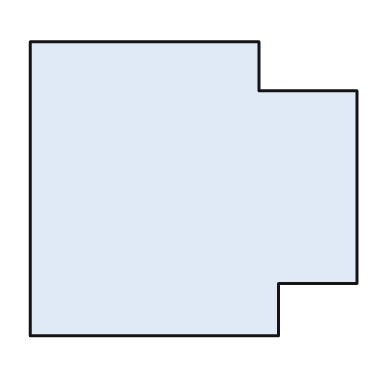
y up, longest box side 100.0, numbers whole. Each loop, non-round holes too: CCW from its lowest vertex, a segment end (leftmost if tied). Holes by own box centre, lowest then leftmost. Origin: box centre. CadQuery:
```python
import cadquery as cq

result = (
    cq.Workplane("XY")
    .moveTo(-50.0, -45.0)
    .lineTo(26.0, -45.0)
    .lineTo(26.0, -29.0)
    .lineTo(50.0, -29.0)
    .lineTo(50.0, 30.0)
    .lineTo(20.0, 30.0)
    .lineTo(20.0, 45.0)
    .lineTo(-50.0, 45.0)
    .close()
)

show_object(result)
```